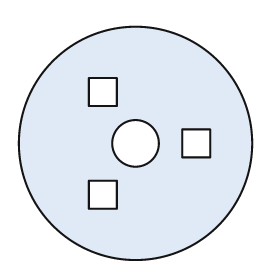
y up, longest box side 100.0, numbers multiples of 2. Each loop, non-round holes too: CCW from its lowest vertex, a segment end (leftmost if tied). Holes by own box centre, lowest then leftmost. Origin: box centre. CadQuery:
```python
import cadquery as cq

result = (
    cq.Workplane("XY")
    .moveTo(0.0, 0.0)
    .circle(50.0)
    .moveTo(-20.0, -28.0)
    .lineTo(-8.0, -28.0)
    .lineTo(-8.0, -16.0)
    .lineTo(-20.0, -16.0)
    .close()
    .moveTo(0.0, 0.0)
    .circle(10.0)
    .moveTo(20.0, -6.0)
    .lineTo(32.0, -6.0)
    .lineTo(32.0, 6.0)
    .lineTo(20.0, 6.0)
    .close()
    .moveTo(-20.0, 16.0)
    .lineTo(-8.0, 16.0)
    .lineTo(-8.0, 28.0)
    .lineTo(-20.0, 28.0)
    .close()
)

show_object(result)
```